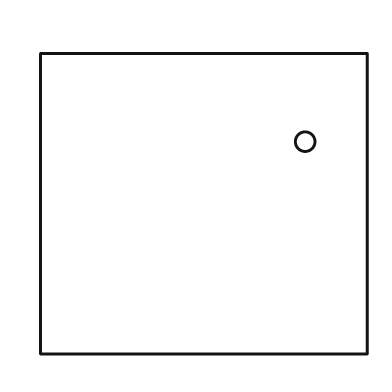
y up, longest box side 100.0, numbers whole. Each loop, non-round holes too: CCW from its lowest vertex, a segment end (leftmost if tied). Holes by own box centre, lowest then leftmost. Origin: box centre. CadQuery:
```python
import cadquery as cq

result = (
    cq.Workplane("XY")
    .moveTo(-50.0, -46.0)
    .lineTo(50.0, -46.0)
    .lineTo(50.0, 46.0)
    .lineTo(-50.0, 46.0)
    .close()
    .moveTo(31.0, 19.0)
    .circle(3.0)
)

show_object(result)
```